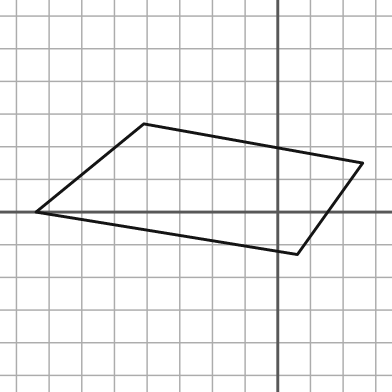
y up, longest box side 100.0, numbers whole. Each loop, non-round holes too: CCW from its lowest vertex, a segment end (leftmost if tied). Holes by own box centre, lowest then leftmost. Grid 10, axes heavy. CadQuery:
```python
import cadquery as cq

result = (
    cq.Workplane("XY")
    .moveTo(6.0, -13.0)
    .lineTo(26.0, 15.0)
    .lineTo(-41.0, 27.0)
    .lineTo(-74.0, 0.0)
    .close()
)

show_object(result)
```